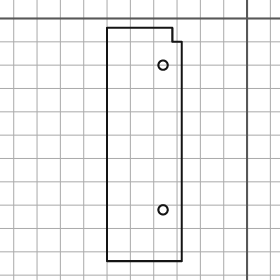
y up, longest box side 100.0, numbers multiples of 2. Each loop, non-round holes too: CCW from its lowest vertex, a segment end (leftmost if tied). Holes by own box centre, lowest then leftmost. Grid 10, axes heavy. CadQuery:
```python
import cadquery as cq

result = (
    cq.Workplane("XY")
    .moveTo(-60.0, -104.0)
    .lineTo(-28.0, -104.0)
    .lineTo(-28.0, -10.0)
    .lineTo(-32.0, -10.0)
    .lineTo(-32.0, -4.0)
    .lineTo(-60.0, -4.0)
    .close()
    .moveTo(-36.0, -82.0)
    .circle(2.0)
    .moveTo(-36.0, -20.0)
    .circle(2.0)
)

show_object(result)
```